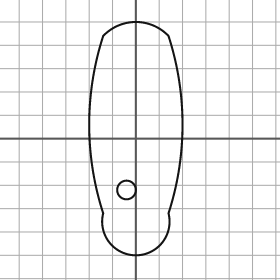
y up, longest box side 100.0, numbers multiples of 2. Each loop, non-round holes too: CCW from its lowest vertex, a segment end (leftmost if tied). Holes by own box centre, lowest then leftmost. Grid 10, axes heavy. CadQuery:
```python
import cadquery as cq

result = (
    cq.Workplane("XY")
    .moveTo(-14.0, -32.0)
    .threePointArc((0.0, -50.0), (14.0, -32.0))
    .threePointArc((20.0, 6.0), (14.0, 44.0))
    .threePointArc((0.0, 50.0), (-14.0, 44.0))
    .threePointArc((-20.0, 6.0), (-14.0, -32.0))
    .close()
    .moveTo(-4.0, -22.0)
    .circle(4.0)
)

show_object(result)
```